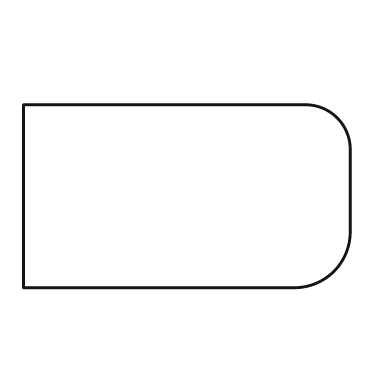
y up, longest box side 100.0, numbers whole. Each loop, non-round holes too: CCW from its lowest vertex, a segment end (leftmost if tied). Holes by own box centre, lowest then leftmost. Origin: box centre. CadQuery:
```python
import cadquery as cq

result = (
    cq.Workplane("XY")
    .moveTo(-50.0, -28.0)
    .lineTo(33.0, -28.0)
    .threePointArc((45.0, -23.0), (50.0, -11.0))
    .lineTo(50.0, 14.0)
    .threePointArc((46.0, 24.0), (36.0, 28.0))
    .lineTo(-50.0, 28.0)
    .close()
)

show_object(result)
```